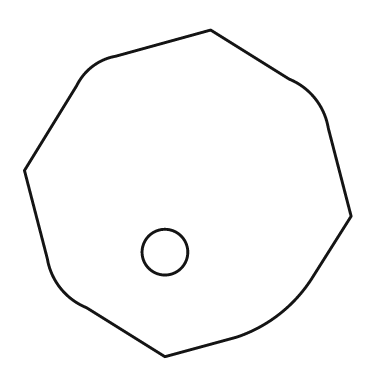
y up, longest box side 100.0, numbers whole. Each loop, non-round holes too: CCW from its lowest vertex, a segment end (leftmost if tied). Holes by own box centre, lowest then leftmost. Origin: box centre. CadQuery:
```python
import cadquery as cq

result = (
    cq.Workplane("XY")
    .moveTo(-7.0, -50.0)
    .lineTo(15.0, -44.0)
    .threePointArc((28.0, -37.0), (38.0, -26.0))
    .lineTo(50.0, -7.0)
    .lineTo(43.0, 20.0)
    .threePointArc((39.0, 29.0), (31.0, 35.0))
    .lineTo(7.0, 50.0)
    .lineTo(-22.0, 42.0)
    .threePointArc((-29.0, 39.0), (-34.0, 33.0))
    .lineTo(-50.0, 7.0)
    .lineTo(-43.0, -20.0)
    .threePointArc((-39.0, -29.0), (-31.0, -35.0))
    .close()
    .moveTo(-7.0, -18.0)
    .circle(7.0)
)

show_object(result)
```